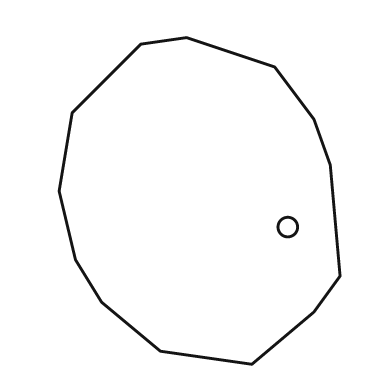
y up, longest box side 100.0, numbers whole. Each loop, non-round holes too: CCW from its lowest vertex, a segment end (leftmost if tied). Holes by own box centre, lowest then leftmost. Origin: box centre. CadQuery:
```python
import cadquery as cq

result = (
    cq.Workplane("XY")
    .moveTo(16.0, -50.0)
    .lineTo(35.0, -34.0)
    .lineTo(43.0, -23.0)
    .lineTo(40.0, 11.0)
    .lineTo(35.0, 25.0)
    .lineTo(23.0, 41.0)
    .lineTo(-4.0, 50.0)
    .lineTo(-18.0, 48.0)
    .lineTo(-39.0, 27.0)
    .lineTo(-43.0, 3.0)
    .lineTo(-38.0, -18.0)
    .lineTo(-30.0, -31.0)
    .lineTo(-12.0, -46.0)
    .close()
    .moveTo(27.0, -8.0)
    .circle(3.0)
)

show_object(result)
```